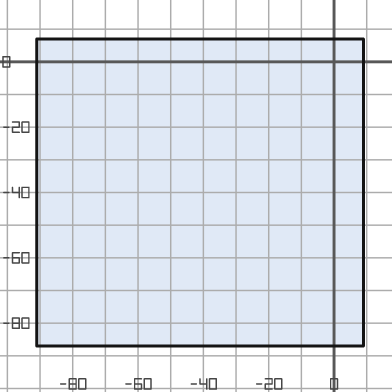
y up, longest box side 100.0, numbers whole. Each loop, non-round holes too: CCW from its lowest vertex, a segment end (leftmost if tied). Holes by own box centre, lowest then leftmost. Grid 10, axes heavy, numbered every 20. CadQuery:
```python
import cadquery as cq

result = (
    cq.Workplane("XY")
    .moveTo(-91.0, -87.0)
    .lineTo(9.0, -87.0)
    .lineTo(9.0, 7.0)
    .lineTo(-91.0, 7.0)
    .close()
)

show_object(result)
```